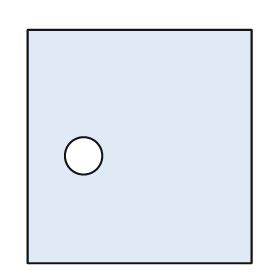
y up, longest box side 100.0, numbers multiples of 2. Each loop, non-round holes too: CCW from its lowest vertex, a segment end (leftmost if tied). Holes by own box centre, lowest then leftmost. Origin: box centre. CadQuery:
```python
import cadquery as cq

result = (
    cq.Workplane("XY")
    .moveTo(-48.0, -50.0)
    .lineTo(48.0, -50.0)
    .lineTo(48.0, 50.0)
    .lineTo(-48.0, 50.0)
    .close()
    .moveTo(-24.0, -4.0)
    .circle(8.0)
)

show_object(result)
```